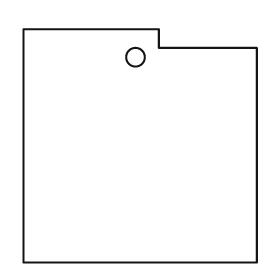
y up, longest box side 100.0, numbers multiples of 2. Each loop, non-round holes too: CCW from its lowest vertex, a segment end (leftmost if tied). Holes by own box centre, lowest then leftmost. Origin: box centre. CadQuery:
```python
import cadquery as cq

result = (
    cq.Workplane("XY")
    .moveTo(-50.0, -50.0)
    .lineTo(50.0, -50.0)
    .lineTo(50.0, 42.0)
    .lineTo(8.0, 42.0)
    .lineTo(8.0, 50.0)
    .lineTo(-50.0, 50.0)
    .close()
    .moveTo(-2.0, 38.0)
    .circle(4.0)
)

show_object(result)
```